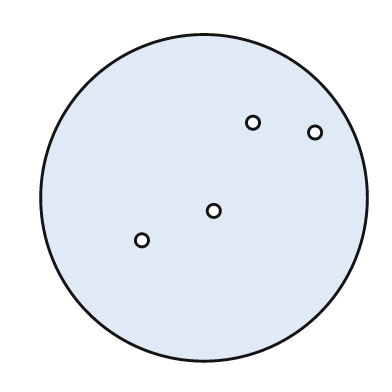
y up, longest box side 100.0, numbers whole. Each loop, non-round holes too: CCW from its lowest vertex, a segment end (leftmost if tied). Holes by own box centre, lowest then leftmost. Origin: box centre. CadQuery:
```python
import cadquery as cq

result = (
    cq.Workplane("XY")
    .moveTo(0.0, 0.0)
    .circle(50.0)
    .moveTo(-19.0, -13.0)
    .circle(2.0)
    .moveTo(3.0, -4.0)
    .circle(2.0)
    .moveTo(34.0, 20.0)
    .circle(2.0)
    .moveTo(15.0, 23.0)
    .circle(2.0)
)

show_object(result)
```